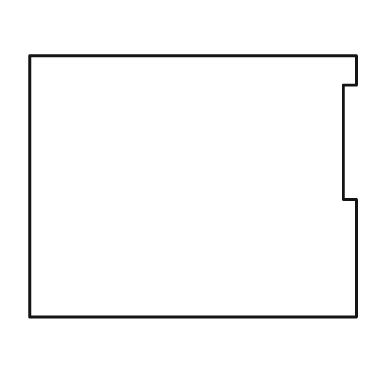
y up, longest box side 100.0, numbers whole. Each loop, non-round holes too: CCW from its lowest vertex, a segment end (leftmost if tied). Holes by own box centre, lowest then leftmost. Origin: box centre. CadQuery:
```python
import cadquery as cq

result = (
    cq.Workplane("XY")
    .moveTo(-50.0, -40.0)
    .lineTo(50.0, -40.0)
    .lineTo(50.0, -4.0)
    .lineTo(46.0, -4.0)
    .lineTo(46.0, 31.0)
    .lineTo(50.0, 31.0)
    .lineTo(50.0, 40.0)
    .lineTo(-50.0, 40.0)
    .close()
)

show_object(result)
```